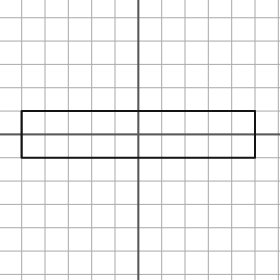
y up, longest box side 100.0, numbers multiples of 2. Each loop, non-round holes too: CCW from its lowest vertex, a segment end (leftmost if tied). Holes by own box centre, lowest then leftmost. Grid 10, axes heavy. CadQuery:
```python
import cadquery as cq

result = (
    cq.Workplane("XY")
    .moveTo(-50.0, -10.0)
    .lineTo(50.0, -10.0)
    .lineTo(50.0, 10.0)
    .lineTo(-50.0, 10.0)
    .close()
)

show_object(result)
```